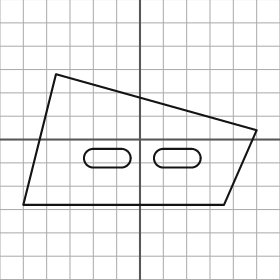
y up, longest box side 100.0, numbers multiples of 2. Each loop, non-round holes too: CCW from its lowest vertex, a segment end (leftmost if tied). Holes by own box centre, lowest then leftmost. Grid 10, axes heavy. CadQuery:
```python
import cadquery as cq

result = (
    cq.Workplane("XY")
    .moveTo(-50.0, -28.0)
    .lineTo(36.0, -28.0)
    .lineTo(50.0, 4.0)
    .lineTo(-36.0, 28.0)
    .close()
    .moveTo(-20.0, -12.0)
    .lineTo(-8.0, -12.0)
    .threePointArc((-4.0, -8.0), (-8.0, -4.0))
    .lineTo(-20.0, -4.0)
    .threePointArc((-24.0, -8.0), (-20.0, -12.0))
    .close()
    .moveTo(10.0, -12.0)
    .lineTo(22.0, -12.0)
    .threePointArc((26.0, -8.0), (22.0, -4.0))
    .lineTo(10.0, -4.0)
    .threePointArc((6.0, -8.0), (10.0, -12.0))
    .close()
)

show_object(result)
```